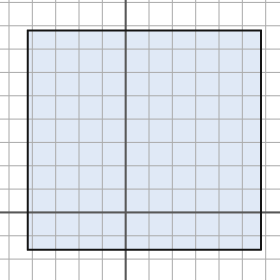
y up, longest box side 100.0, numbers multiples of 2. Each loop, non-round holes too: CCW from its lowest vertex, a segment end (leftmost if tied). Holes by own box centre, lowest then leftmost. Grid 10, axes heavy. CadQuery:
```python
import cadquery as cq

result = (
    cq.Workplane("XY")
    .moveTo(-42.0, -16.0)
    .lineTo(58.0, -16.0)
    .lineTo(58.0, 78.0)
    .lineTo(-42.0, 78.0)
    .close()
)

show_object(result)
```